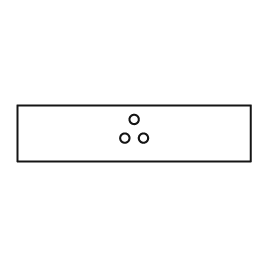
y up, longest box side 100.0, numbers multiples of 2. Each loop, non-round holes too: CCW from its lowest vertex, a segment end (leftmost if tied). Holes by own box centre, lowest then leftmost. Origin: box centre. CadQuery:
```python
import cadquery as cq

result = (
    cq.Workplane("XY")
    .moveTo(-50.0, -12.0)
    .lineTo(50.0, -12.0)
    .lineTo(50.0, 12.0)
    .lineTo(-50.0, 12.0)
    .close()
    .moveTo(-4.0, -2.0)
    .circle(2.0)
    .moveTo(4.0, -2.0)
    .circle(2.0)
    .moveTo(0.0, 6.0)
    .circle(2.0)
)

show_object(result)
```